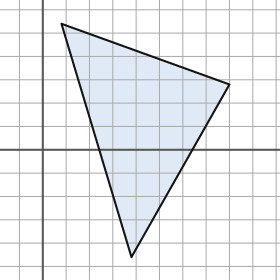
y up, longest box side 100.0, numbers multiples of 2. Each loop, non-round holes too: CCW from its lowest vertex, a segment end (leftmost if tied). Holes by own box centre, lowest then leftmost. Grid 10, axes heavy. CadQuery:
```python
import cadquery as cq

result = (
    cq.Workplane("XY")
    .moveTo(38.0, -46.0)
    .lineTo(80.0, 28.0)
    .lineTo(8.0, 54.0)
    .close()
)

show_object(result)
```